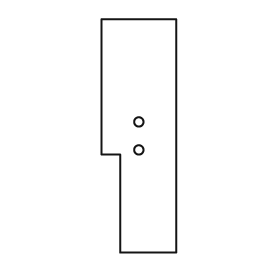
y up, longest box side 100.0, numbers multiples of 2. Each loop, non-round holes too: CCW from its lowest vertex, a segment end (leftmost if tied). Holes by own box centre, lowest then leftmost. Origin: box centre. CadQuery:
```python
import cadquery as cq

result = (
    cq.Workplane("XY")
    .moveTo(-8.0, -50.0)
    .lineTo(16.0, -50.0)
    .lineTo(16.0, 50.0)
    .lineTo(-16.0, 50.0)
    .lineTo(-16.0, -8.0)
    .lineTo(-8.0, -8.0)
    .close()
    .moveTo(0.0, -6.0)
    .circle(2.0)
    .moveTo(0.0, 6.0)
    .circle(2.0)
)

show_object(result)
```